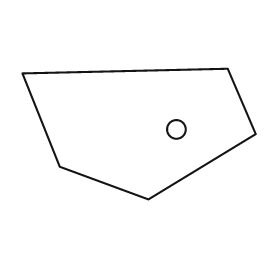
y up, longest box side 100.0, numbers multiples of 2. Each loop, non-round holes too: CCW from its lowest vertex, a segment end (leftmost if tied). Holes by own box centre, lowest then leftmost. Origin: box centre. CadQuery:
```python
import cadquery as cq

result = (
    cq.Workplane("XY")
    .moveTo(4.0, -28.0)
    .lineTo(50.0, 0.0)
    .lineTo(38.0, 28.0)
    .lineTo(-50.0, 26.0)
    .lineTo(-34.0, -14.0)
    .close()
    .moveTo(16.0, 2.0)
    .circle(4.0)
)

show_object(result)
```